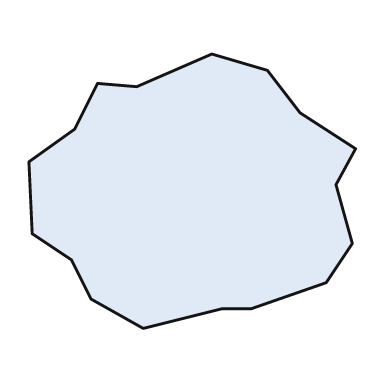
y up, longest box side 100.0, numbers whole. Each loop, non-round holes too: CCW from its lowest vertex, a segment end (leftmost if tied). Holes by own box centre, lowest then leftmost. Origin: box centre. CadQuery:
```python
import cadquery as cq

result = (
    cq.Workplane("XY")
    .moveTo(-15.0, -42.0)
    .lineTo(9.0, -36.0)
    .lineTo(18.0, -36.0)
    .lineTo(41.0, -28.0)
    .lineTo(49.0, -16.0)
    .lineTo(44.0, 2.0)
    .lineTo(50.0, 13.0)
    .lineTo(33.0, 24.0)
    .lineTo(23.0, 37.0)
    .lineTo(6.0, 42.0)
    .lineTo(-17.0, 32.0)
    .lineTo(-29.0, 33.0)
    .lineTo(-36.0, 19.0)
    .lineTo(-50.0, 9.0)
    .lineTo(-49.0, -13.0)
    .lineTo(-37.0, -21.0)
    .lineTo(-31.0, -33.0)
    .close()
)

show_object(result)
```